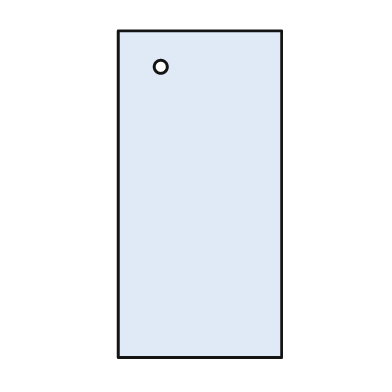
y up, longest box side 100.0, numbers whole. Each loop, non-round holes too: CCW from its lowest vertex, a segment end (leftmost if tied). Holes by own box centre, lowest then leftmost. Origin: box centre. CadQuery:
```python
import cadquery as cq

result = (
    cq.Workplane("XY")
    .moveTo(-25.0, -50.0)
    .lineTo(25.0, -50.0)
    .lineTo(25.0, 50.0)
    .lineTo(-25.0, 50.0)
    .close()
    .moveTo(-12.0, 39.0)
    .circle(2.0)
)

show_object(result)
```